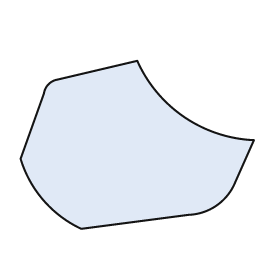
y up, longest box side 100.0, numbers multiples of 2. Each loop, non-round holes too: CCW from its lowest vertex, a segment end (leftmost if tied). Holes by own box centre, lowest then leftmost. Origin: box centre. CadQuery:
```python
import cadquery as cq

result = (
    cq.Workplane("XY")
    .moveTo(-24.0, -36.0)
    .lineTo(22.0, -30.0)
    .threePointArc((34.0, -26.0), (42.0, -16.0))
    .lineTo(50.0, 2.0)
    .threePointArc((20.0, 12.0), (0.0, 36.0))
    .lineTo(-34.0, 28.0)
    .threePointArc((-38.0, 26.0), (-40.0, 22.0))
    .lineTo(-50.0, -6.0)
    .threePointArc((-40.0, -24.0), (-24.0, -36.0))
    .close()
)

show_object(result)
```